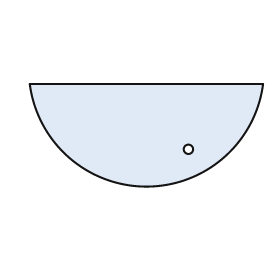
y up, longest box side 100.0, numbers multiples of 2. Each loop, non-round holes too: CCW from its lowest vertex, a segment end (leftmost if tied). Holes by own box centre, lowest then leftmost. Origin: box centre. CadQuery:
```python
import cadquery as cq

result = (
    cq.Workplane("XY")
    .moveTo(-50.0, 22.0)
    .threePointArc((0.0, -22.0), (50.0, 22.0))
    .close()
    .moveTo(18.0, -6.0)
    .circle(2.0)
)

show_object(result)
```